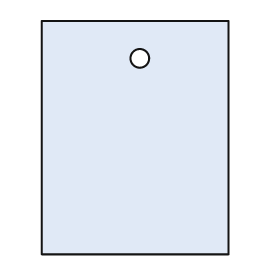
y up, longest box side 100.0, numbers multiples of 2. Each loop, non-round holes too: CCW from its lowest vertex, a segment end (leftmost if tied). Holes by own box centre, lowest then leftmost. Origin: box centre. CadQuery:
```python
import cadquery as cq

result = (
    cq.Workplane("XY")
    .moveTo(-40.0, -50.0)
    .lineTo(40.0, -50.0)
    .lineTo(40.0, 50.0)
    .lineTo(-40.0, 50.0)
    .close()
    .moveTo(2.0, 34.0)
    .circle(4.0)
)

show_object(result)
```